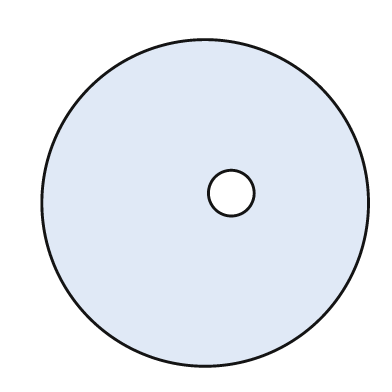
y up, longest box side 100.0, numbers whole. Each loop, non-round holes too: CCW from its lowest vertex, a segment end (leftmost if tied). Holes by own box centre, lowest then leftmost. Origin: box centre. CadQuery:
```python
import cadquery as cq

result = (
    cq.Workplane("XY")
    .moveTo(0.0, 0.0)
    .circle(50.0)
    .moveTo(8.0, 3.0)
    .circle(7.0)
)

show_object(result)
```